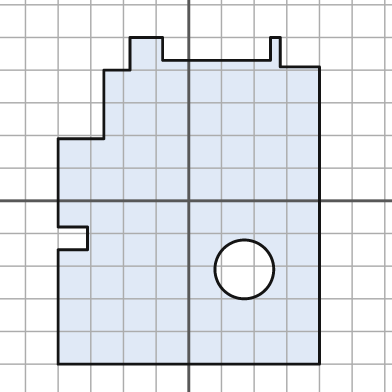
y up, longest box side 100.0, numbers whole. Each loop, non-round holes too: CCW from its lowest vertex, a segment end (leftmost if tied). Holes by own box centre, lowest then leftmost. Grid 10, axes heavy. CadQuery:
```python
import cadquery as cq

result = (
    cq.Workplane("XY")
    .moveTo(-40.0, -50.0)
    .lineTo(40.0, -50.0)
    .lineTo(40.0, 41.0)
    .lineTo(28.0, 41.0)
    .lineTo(28.0, 50.0)
    .lineTo(25.0, 50.0)
    .lineTo(25.0, 43.0)
    .lineTo(-8.0, 43.0)
    .lineTo(-8.0, 50.0)
    .lineTo(-18.0, 50.0)
    .lineTo(-18.0, 40.0)
    .lineTo(-26.0, 40.0)
    .lineTo(-26.0, 19.0)
    .lineTo(-40.0, 19.0)
    .lineTo(-40.0, -8.0)
    .lineTo(-31.0, -8.0)
    .lineTo(-31.0, -15.0)
    .lineTo(-40.0, -15.0)
    .close()
    .moveTo(17.0, -21.0)
    .circle(9.0)
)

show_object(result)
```